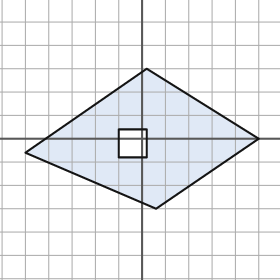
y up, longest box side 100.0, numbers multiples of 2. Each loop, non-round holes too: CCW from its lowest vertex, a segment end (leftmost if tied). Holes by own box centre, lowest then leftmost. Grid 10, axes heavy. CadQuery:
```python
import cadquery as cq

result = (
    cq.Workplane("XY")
    .moveTo(6.0, -30.0)
    .lineTo(50.0, 0.0)
    .lineTo(2.0, 30.0)
    .lineTo(-50.0, -6.0)
    .close()
    .moveTo(-10.0, -8.0)
    .lineTo(2.0, -8.0)
    .lineTo(2.0, 4.0)
    .lineTo(-10.0, 4.0)
    .close()
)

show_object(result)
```